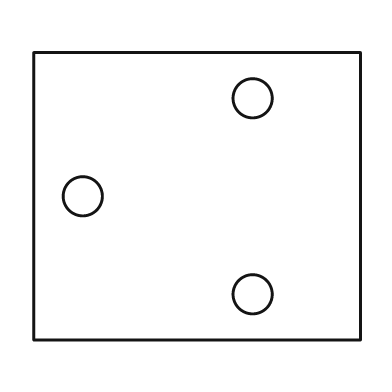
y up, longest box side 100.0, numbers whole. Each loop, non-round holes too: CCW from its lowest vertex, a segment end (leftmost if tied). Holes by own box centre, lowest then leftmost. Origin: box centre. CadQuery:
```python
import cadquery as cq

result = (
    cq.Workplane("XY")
    .moveTo(-50.0, -44.0)
    .lineTo(50.0, -44.0)
    .lineTo(50.0, 44.0)
    .lineTo(-50.0, 44.0)
    .close()
    .moveTo(17.0, -30.0)
    .circle(6.0)
    .moveTo(-35.0, 0.0)
    .circle(6.0)
    .moveTo(17.0, 30.0)
    .circle(6.0)
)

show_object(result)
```